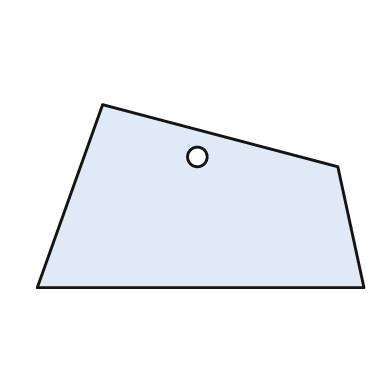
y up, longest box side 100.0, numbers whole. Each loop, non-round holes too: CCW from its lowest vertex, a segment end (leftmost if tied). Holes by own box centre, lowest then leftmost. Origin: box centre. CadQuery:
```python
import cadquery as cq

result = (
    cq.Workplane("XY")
    .moveTo(-50.0, -28.0)
    .lineTo(50.0, -28.0)
    .lineTo(42.0, 9.0)
    .lineTo(-30.0, 28.0)
    .close()
    .moveTo(-1.0, 12.0)
    .circle(3.0)
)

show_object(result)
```